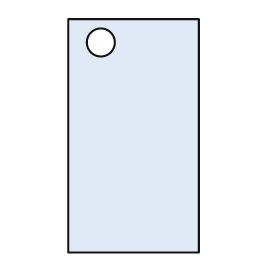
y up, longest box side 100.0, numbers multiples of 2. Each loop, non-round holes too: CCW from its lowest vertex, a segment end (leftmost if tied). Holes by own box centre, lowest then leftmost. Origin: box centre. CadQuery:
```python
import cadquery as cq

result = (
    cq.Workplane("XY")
    .moveTo(-28.0, -50.0)
    .lineTo(28.0, -50.0)
    .lineTo(28.0, 50.0)
    .lineTo(-28.0, 50.0)
    .close()
    .moveTo(-14.0, 40.0)
    .circle(6.0)
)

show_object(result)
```